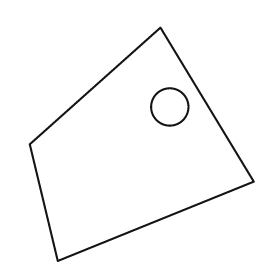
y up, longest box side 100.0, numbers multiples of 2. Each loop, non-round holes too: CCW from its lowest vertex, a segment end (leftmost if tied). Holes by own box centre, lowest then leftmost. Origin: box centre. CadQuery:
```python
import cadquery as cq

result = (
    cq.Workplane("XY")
    .moveTo(-36.0, -50.0)
    .lineTo(48.0, -16.0)
    .lineTo(8.0, 50.0)
    .lineTo(-48.0, 0.0)
    .close()
    .moveTo(12.0, 16.0)
    .circle(8.0)
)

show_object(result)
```